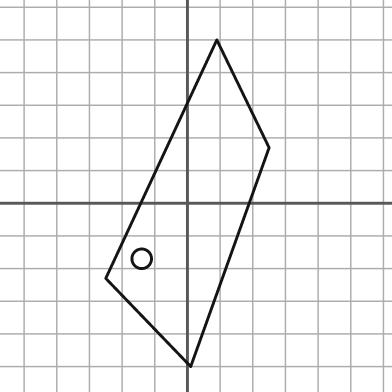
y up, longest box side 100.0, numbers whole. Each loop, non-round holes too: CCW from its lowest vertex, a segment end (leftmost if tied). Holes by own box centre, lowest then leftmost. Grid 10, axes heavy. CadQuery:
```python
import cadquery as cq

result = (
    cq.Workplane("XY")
    .moveTo(1.0, -50.0)
    .lineTo(25.0, 17.0)
    .lineTo(9.0, 50.0)
    .lineTo(-25.0, -23.0)
    .close()
    .moveTo(-14.0, -17.0)
    .circle(3.0)
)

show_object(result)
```